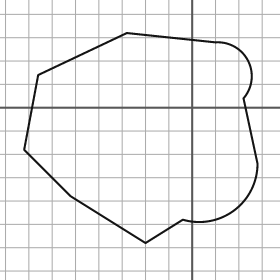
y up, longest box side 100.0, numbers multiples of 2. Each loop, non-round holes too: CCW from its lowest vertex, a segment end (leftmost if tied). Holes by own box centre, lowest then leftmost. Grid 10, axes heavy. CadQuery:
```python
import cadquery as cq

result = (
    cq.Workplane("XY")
    .moveTo(-20.0, -58.0)
    .lineTo(-4.0, -48.0)
    .threePointArc((18.0, -44.0), (28.0, -24.0))
    .lineTo(22.0, 4.0)
    .threePointArc((24.0, 20.0), (10.0, 28.0))
    .lineTo(-28.0, 32.0)
    .lineTo(-66.0, 14.0)
    .lineTo(-72.0, -18.0)
    .lineTo(-52.0, -38.0)
    .close()
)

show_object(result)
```